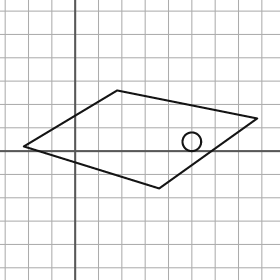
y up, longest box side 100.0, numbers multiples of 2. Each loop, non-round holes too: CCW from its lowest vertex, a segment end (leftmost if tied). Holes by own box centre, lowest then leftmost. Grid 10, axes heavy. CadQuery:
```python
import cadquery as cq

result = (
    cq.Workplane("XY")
    .moveTo(36.0, -16.0)
    .lineTo(78.0, 14.0)
    .lineTo(18.0, 26.0)
    .lineTo(-22.0, 2.0)
    .close()
    .moveTo(50.0, 4.0)
    .circle(4.0)
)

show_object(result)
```